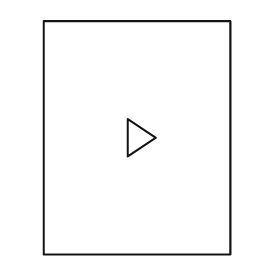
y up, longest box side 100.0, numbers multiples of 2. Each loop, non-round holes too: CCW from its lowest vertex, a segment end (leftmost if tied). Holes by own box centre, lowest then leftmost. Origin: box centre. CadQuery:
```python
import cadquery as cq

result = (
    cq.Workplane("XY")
    .moveTo(-40.0, -50.0)
    .lineTo(40.0, -50.0)
    .lineTo(40.0, 50.0)
    .lineTo(-40.0, 50.0)
    .close()
    .moveTo(-4.0, -8.0)
    .lineTo(8.0, 0.0)
    .lineTo(-4.0, 8.0)
    .close()
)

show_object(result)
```